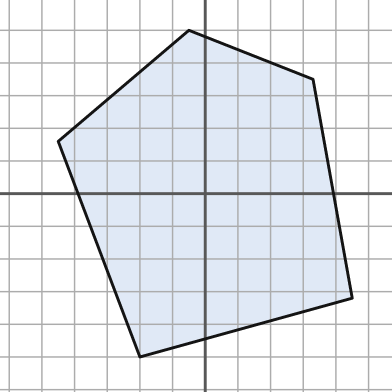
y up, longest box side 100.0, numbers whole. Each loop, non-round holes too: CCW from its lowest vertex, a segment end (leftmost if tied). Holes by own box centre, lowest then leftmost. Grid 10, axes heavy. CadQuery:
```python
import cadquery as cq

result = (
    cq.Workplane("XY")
    .moveTo(-20.0, -50.0)
    .lineTo(45.0, -32.0)
    .lineTo(33.0, 35.0)
    .lineTo(-5.0, 50.0)
    .lineTo(-45.0, 16.0)
    .close()
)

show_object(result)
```